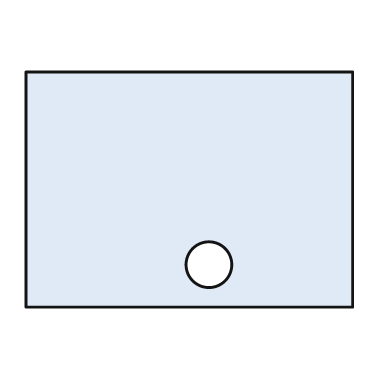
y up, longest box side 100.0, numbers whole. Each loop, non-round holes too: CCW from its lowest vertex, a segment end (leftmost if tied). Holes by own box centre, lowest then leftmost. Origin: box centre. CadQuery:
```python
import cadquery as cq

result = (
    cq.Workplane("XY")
    .moveTo(-50.0, -36.0)
    .lineTo(50.0, -36.0)
    .lineTo(50.0, 36.0)
    .lineTo(-50.0, 36.0)
    .close()
    .moveTo(6.0, -23.0)
    .circle(7.0)
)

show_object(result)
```